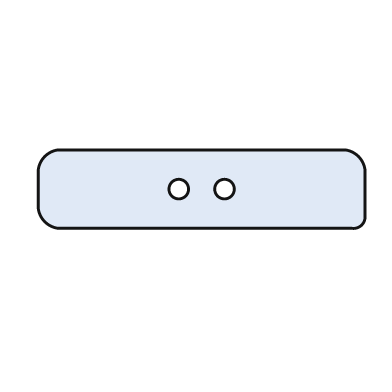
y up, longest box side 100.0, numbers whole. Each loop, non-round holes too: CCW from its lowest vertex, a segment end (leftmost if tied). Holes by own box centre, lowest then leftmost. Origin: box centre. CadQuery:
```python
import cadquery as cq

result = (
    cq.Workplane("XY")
    .moveTo(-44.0, -12.0)
    .lineTo(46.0, -12.0)
    .threePointArc((49.0, -11.0), (50.0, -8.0))
    .lineTo(50.0, 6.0)
    .threePointArc((48.0, 10.0), (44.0, 12.0))
    .lineTo(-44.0, 12.0)
    .threePointArc((-48.0, 10.0), (-50.0, 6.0))
    .lineTo(-50.0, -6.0)
    .threePointArc((-48.0, -10.0), (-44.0, -12.0))
    .close()
    .moveTo(-7.0, 0.0)
    .circle(3.0)
    .moveTo(7.0, 0.0)
    .circle(3.0)
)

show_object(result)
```